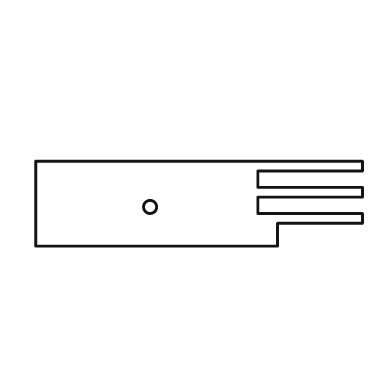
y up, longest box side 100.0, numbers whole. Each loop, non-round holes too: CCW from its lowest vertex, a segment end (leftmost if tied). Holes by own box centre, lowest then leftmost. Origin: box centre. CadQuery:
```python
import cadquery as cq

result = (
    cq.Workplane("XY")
    .moveTo(-50.0, -13.0)
    .lineTo(24.0, -13.0)
    .lineTo(24.0, -6.0)
    .lineTo(50.0, -6.0)
    .lineTo(50.0, -3.0)
    .lineTo(18.0, -3.0)
    .lineTo(18.0, 2.0)
    .lineTo(50.0, 2.0)
    .lineTo(50.0, 5.0)
    .lineTo(18.0, 5.0)
    .lineTo(18.0, 10.0)
    .lineTo(50.0, 10.0)
    .lineTo(50.0, 13.0)
    .lineTo(-50.0, 13.0)
    .close()
    .moveTo(-15.0, -1.0)
    .circle(2.0)
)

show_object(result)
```